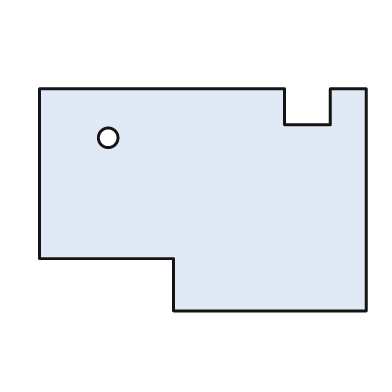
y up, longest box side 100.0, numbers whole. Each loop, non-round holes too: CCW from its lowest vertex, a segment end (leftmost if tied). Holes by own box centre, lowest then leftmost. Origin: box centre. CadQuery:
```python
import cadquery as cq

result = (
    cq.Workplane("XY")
    .moveTo(-9.0, -34.0)
    .lineTo(50.0, -34.0)
    .lineTo(50.0, 34.0)
    .lineTo(39.0, 34.0)
    .lineTo(39.0, 23.0)
    .lineTo(25.0, 23.0)
    .lineTo(25.0, 34.0)
    .lineTo(-50.0, 34.0)
    .lineTo(-50.0, -18.0)
    .lineTo(-9.0, -18.0)
    .close()
    .moveTo(-29.0, 19.0)
    .circle(3.0)
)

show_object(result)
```